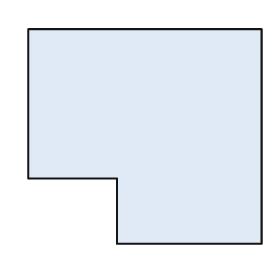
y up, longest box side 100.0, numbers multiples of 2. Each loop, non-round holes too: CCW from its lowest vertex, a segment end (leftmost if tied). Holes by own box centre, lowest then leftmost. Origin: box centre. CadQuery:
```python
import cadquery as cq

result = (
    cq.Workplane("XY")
    .moveTo(-12.0, -46.0)
    .lineTo(50.0, -46.0)
    .lineTo(50.0, 46.0)
    .lineTo(-50.0, 46.0)
    .lineTo(-50.0, -18.0)
    .lineTo(-12.0, -18.0)
    .close()
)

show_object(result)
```